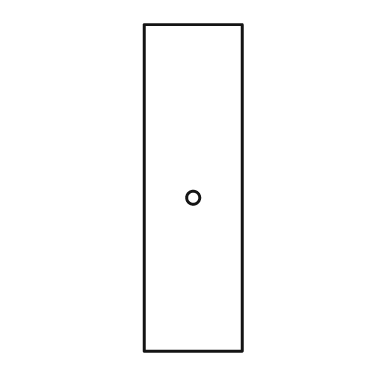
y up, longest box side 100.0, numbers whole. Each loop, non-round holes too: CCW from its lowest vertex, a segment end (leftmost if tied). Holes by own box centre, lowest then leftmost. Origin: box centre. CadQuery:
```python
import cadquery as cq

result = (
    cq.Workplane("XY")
    .moveTo(-15.0, -50.0)
    .lineTo(15.0, -50.0)
    .lineTo(15.0, 50.0)
    .lineTo(-15.0, 50.0)
    .close()
    .moveTo(0.0, -3.0)
    .circle(2.0)
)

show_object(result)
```